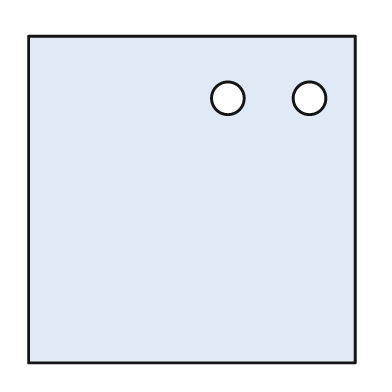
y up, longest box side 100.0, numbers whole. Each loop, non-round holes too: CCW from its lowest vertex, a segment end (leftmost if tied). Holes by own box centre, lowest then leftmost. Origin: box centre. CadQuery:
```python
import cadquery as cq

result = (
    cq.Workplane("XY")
    .moveTo(-50.0, -50.0)
    .lineTo(50.0, -50.0)
    .lineTo(50.0, 50.0)
    .lineTo(-50.0, 50.0)
    .close()
    .moveTo(11.0, 31.0)
    .circle(5.0)
    .moveTo(36.0, 31.0)
    .circle(5.0)
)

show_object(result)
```